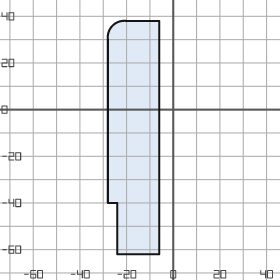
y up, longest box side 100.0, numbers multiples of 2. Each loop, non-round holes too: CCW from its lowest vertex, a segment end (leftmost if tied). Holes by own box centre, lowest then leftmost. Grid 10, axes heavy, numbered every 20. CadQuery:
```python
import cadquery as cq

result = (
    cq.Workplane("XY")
    .moveTo(-24.0, -62.0)
    .lineTo(-6.0, -62.0)
    .lineTo(-6.0, 38.0)
    .lineTo(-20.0, 38.0)
    .threePointArc((-26.0, 36.0), (-28.0, 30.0))
    .lineTo(-28.0, -40.0)
    .lineTo(-24.0, -40.0)
    .close()
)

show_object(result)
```